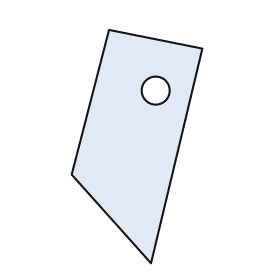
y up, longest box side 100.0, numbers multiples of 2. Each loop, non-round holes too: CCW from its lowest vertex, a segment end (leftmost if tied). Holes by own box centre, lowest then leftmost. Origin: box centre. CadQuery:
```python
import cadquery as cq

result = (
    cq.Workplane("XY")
    .moveTo(6.0, -50.0)
    .lineTo(28.0, 42.0)
    .lineTo(-12.0, 50.0)
    .lineTo(-28.0, -12.0)
    .close()
    .moveTo(8.0, 24.0)
    .circle(6.0)
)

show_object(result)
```